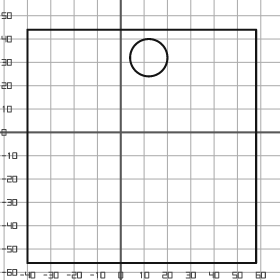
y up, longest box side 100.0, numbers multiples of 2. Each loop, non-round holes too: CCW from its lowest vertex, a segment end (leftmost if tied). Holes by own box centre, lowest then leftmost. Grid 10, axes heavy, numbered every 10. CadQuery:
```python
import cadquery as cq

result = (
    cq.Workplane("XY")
    .moveTo(-40.0, -56.0)
    .lineTo(58.0, -56.0)
    .lineTo(58.0, 44.0)
    .lineTo(-40.0, 44.0)
    .close()
    .moveTo(12.0, 32.0)
    .circle(8.0)
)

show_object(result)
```